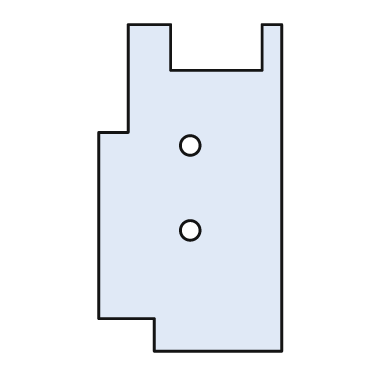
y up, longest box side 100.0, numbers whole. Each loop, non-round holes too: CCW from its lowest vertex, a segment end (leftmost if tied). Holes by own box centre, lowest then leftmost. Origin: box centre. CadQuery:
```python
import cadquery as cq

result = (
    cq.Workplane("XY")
    .moveTo(-11.0, -50.0)
    .lineTo(28.0, -50.0)
    .lineTo(28.0, 50.0)
    .lineTo(22.0, 50.0)
    .lineTo(22.0, 36.0)
    .lineTo(-6.0, 36.0)
    .lineTo(-6.0, 50.0)
    .lineTo(-19.0, 50.0)
    .lineTo(-19.0, 17.0)
    .lineTo(-28.0, 17.0)
    .lineTo(-28.0, -40.0)
    .lineTo(-11.0, -40.0)
    .close()
    .moveTo(0.0, -13.0)
    .circle(3.0)
    .moveTo(0.0, 13.0)
    .circle(3.0)
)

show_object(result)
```